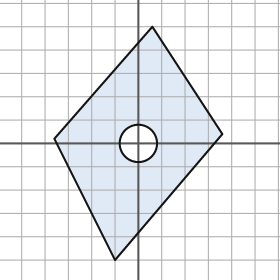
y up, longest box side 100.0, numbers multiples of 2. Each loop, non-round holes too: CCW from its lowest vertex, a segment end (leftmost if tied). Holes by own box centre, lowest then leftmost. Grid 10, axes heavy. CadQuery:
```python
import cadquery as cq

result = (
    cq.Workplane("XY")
    .moveTo(-10.0, -50.0)
    .lineTo(36.0, 4.0)
    .lineTo(6.0, 50.0)
    .lineTo(-36.0, 2.0)
    .close()
    .moveTo(0.0, 0.0)
    .circle(8.0)
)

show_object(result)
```